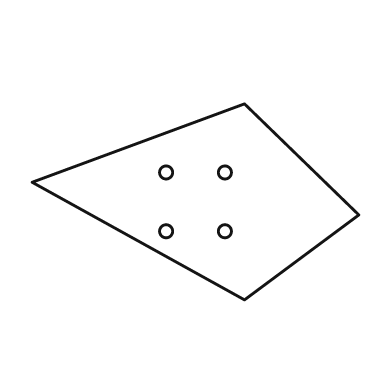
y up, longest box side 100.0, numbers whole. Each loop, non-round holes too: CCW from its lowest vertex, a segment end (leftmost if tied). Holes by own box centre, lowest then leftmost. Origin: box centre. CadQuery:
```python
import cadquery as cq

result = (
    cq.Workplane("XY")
    .moveTo(15.0, -30.0)
    .lineTo(50.0, -4.0)
    .lineTo(15.0, 30.0)
    .lineTo(-50.0, 6.0)
    .close()
    .moveTo(-9.0, -9.0)
    .circle(2.0)
    .moveTo(9.0, -9.0)
    .circle(2.0)
    .moveTo(-9.0, 9.0)
    .circle(2.0)
    .moveTo(9.0, 9.0)
    .circle(2.0)
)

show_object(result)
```